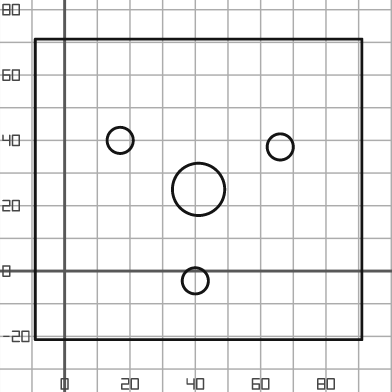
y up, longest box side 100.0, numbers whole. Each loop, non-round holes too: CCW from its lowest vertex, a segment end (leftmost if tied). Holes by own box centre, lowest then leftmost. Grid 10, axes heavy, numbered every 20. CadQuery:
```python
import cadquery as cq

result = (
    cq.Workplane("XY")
    .moveTo(-9.0, -21.0)
    .lineTo(91.0, -21.0)
    .lineTo(91.0, 71.0)
    .lineTo(-9.0, 71.0)
    .close()
    .moveTo(40.0, -3.0)
    .circle(4.0)
    .moveTo(41.0, 25.0)
    .circle(8.0)
    .moveTo(66.0, 38.0)
    .circle(4.0)
    .moveTo(17.0, 40.0)
    .circle(4.0)
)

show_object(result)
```